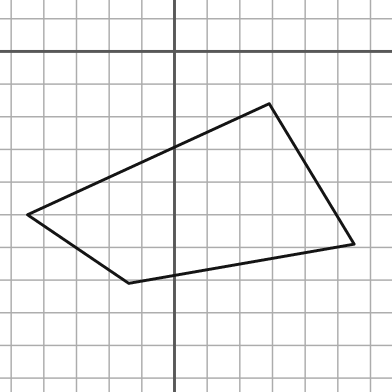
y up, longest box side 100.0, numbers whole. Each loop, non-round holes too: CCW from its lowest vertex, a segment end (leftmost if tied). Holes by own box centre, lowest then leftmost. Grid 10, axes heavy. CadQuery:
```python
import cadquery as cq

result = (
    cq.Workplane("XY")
    .moveTo(-14.0, -71.0)
    .lineTo(55.0, -59.0)
    .lineTo(29.0, -16.0)
    .lineTo(-45.0, -50.0)
    .close()
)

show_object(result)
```